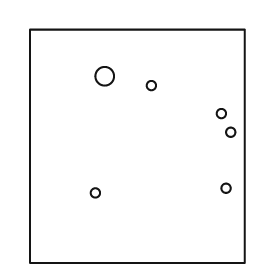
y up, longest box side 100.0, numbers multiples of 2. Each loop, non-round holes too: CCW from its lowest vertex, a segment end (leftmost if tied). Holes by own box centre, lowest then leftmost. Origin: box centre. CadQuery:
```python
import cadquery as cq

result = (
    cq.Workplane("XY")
    .moveTo(-46.0, -50.0)
    .lineTo(46.0, -50.0)
    .lineTo(46.0, 50.0)
    .lineTo(-46.0, 50.0)
    .close()
    .moveTo(-18.0, -20.0)
    .circle(2.0)
    .moveTo(38.0, -18.0)
    .circle(2.0)
    .moveTo(40.0, 6.0)
    .circle(2.0)
    .moveTo(36.0, 14.0)
    .circle(2.0)
    .moveTo(6.0, 26.0)
    .circle(2.0)
    .moveTo(-14.0, 30.0)
    .circle(4.0)
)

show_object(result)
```